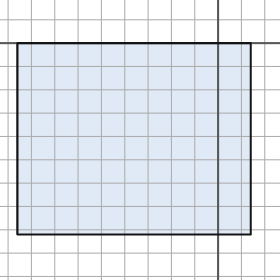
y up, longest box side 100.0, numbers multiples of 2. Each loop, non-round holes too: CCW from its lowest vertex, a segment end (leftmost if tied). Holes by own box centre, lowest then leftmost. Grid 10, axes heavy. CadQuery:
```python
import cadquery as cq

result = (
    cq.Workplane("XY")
    .moveTo(-86.0, -82.0)
    .lineTo(14.0, -82.0)
    .lineTo(14.0, 0.0)
    .lineTo(-86.0, 0.0)
    .close()
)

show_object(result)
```